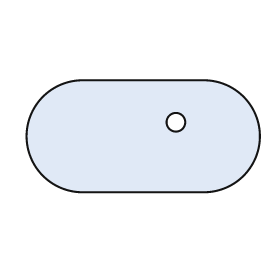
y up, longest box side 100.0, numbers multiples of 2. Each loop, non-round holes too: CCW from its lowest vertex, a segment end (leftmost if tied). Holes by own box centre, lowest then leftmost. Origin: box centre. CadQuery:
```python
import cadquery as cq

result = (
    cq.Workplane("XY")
    .moveTo(-26.0, -24.0)
    .lineTo(26.0, -24.0)
    .threePointArc((50.0, 0.0), (26.0, 24.0))
    .lineTo(-26.0, 24.0)
    .threePointArc((-50.0, 0.0), (-26.0, -24.0))
    .close()
    .moveTo(14.0, 6.0)
    .circle(4.0)
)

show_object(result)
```